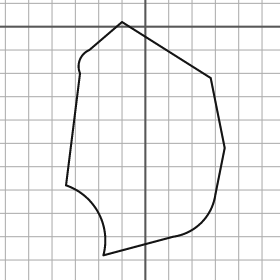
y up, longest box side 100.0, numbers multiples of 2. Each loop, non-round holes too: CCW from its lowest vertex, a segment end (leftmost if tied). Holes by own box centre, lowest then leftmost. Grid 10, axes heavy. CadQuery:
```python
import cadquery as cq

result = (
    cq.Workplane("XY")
    .moveTo(-18.0, -98.0)
    .lineTo(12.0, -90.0)
    .threePointArc((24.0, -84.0), (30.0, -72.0))
    .lineTo(34.0, -52.0)
    .lineTo(28.0, -22.0)
    .lineTo(-10.0, 2.0)
    .lineTo(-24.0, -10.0)
    .threePointArc((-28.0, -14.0), (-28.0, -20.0))
    .lineTo(-34.0, -68.0)
    .threePointArc((-20.0, -80.0), (-18.0, -98.0))
    .close()
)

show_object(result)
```